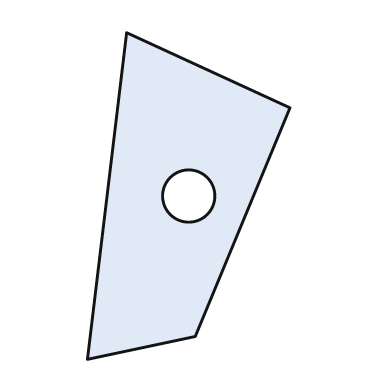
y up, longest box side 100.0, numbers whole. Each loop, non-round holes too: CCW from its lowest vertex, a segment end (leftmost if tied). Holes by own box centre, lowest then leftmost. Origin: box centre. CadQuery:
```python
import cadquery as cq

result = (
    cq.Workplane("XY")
    .moveTo(-31.0, -50.0)
    .lineTo(2.0, -43.0)
    .lineTo(31.0, 27.0)
    .lineTo(-19.0, 50.0)
    .close()
    .moveTo(0.0, 0.0)
    .circle(8.0)
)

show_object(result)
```